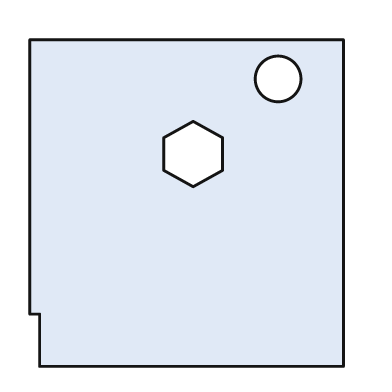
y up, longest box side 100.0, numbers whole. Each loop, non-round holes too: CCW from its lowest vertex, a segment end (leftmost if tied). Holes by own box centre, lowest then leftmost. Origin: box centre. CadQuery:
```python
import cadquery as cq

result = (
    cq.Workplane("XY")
    .moveTo(-45.0, -50.0)
    .lineTo(48.0, -50.0)
    .lineTo(48.0, 50.0)
    .lineTo(-48.0, 50.0)
    .lineTo(-48.0, -34.0)
    .lineTo(-45.0, -34.0)
    .close()
    .moveTo(2.0, 5.0)
    .lineTo(11.0, 10.0)
    .lineTo(11.0, 20.0)
    .lineTo(2.0, 25.0)
    .lineTo(-7.0, 20.0)
    .lineTo(-7.0, 10.0)
    .close()
    .moveTo(28.0, 38.0)
    .circle(7.0)
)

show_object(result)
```